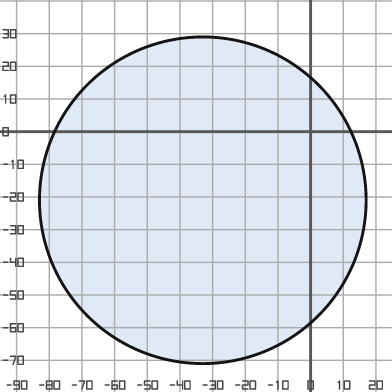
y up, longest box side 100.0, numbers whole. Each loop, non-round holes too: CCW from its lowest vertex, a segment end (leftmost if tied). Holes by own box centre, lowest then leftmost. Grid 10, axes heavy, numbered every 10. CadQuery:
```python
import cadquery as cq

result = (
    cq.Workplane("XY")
    .moveTo(-33.0, -21.0)
    .circle(50.0)
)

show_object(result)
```